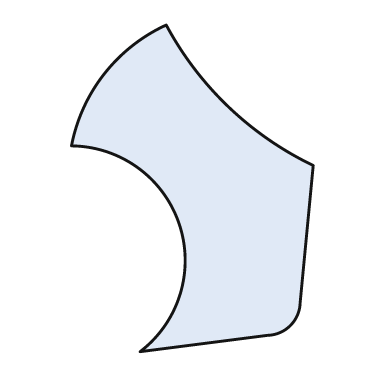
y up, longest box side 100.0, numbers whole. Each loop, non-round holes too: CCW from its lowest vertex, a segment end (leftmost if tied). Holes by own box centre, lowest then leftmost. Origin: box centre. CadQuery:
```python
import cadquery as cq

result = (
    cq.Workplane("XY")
    .moveTo(-16.0, -50.0)
    .lineTo(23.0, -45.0)
    .threePointArc((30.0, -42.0), (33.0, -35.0))
    .lineTo(37.0, 7.0)
    .threePointArc((11.0, 25.0), (-8.0, 50.0))
    .threePointArc((-27.0, 35.0), (-37.0, 13.0))
    .threePointArc((-4.0, -11.0), (-16.0, -50.0))
    .close()
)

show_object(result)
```